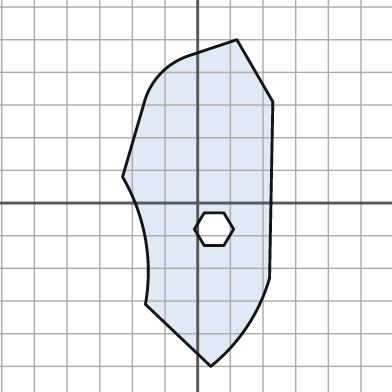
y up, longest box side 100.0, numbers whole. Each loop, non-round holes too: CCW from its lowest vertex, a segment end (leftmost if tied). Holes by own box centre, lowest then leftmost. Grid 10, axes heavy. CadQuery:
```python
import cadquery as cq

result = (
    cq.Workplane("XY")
    .moveTo(4.0, -50.0)
    .threePointArc((15.0, -38.0), (22.0, -23.0))
    .lineTo(23.0, 31.0)
    .lineTo(12.0, 50.0)
    .lineTo(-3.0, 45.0)
    .threePointArc((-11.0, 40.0), (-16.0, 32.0))
    .lineTo(-23.0, 8.0)
    .threePointArc((-16.0, -11.0), (-16.0, -31.0))
    .close()
    .moveTo(2.0, -13.0)
    .lineTo(8.0, -13.0)
    .lineTo(11.0, -8.0)
    .lineTo(8.0, -3.0)
    .lineTo(2.0, -3.0)
    .lineTo(-1.0, -8.0)
    .close()
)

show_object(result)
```